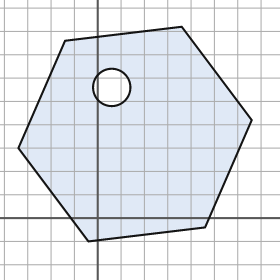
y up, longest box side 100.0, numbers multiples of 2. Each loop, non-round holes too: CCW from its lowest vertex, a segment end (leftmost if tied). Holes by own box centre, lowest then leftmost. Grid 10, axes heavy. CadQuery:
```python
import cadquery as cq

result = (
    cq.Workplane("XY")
    .moveTo(-4.0, -10.0)
    .lineTo(46.0, -4.0)
    .lineTo(66.0, 42.0)
    .lineTo(36.0, 82.0)
    .lineTo(-14.0, 76.0)
    .lineTo(-34.0, 30.0)
    .close()
    .moveTo(6.0, 56.0)
    .circle(8.0)
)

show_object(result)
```